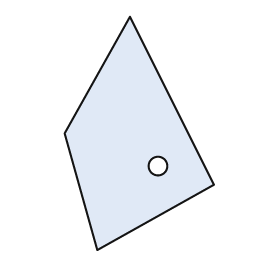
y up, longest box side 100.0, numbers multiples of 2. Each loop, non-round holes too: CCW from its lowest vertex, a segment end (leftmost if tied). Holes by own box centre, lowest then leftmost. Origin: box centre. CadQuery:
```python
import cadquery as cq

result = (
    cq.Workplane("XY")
    .moveTo(-18.0, -50.0)
    .lineTo(32.0, -22.0)
    .lineTo(-4.0, 50.0)
    .lineTo(-32.0, 0.0)
    .close()
    .moveTo(8.0, -14.0)
    .circle(4.0)
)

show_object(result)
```